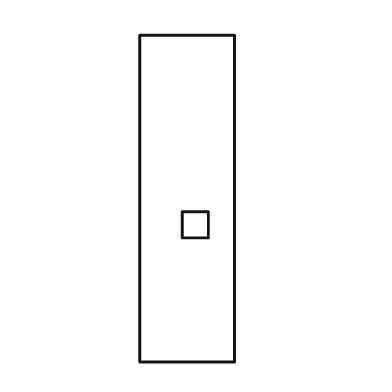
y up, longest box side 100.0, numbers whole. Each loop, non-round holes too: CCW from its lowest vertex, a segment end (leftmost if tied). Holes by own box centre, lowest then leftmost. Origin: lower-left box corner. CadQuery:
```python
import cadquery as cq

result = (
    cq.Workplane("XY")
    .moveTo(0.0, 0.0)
    .lineTo(29.0, 0.0)
    .lineTo(29.0, 100.0)
    .lineTo(0.0, 100.0)
    .close()
    .moveTo(13.0, 38.0)
    .lineTo(21.0, 38.0)
    .lineTo(21.0, 46.0)
    .lineTo(13.0, 46.0)
    .close()
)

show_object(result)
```